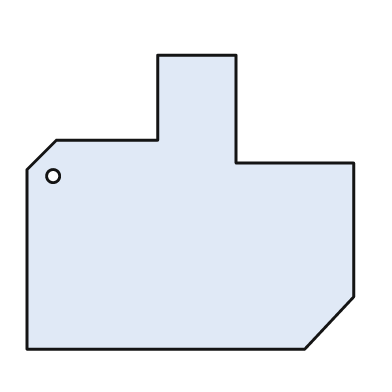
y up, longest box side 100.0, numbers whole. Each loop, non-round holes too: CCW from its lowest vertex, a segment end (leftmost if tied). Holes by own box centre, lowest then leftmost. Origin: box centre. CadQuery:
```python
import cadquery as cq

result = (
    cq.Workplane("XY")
    .moveTo(-50.0, -45.0)
    .lineTo(35.0, -45.0)
    .lineTo(50.0, -29.0)
    .lineTo(50.0, 12.0)
    .lineTo(14.0, 12.0)
    .lineTo(14.0, 45.0)
    .lineTo(-10.0, 45.0)
    .lineTo(-10.0, 19.0)
    .lineTo(-41.0, 19.0)
    .lineTo(-50.0, 10.0)
    .close()
    .moveTo(-42.0, 8.0)
    .circle(2.0)
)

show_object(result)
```